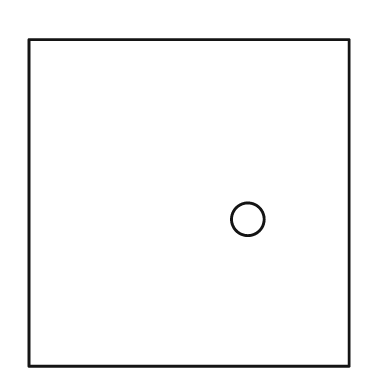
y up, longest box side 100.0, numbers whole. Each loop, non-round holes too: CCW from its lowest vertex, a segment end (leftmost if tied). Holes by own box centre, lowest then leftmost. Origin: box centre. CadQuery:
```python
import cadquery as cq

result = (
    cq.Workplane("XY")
    .moveTo(-49.0, -50.0)
    .lineTo(49.0, -50.0)
    .lineTo(49.0, 50.0)
    .lineTo(-49.0, 50.0)
    .close()
    .moveTo(18.0, -5.0)
    .circle(5.0)
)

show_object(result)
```